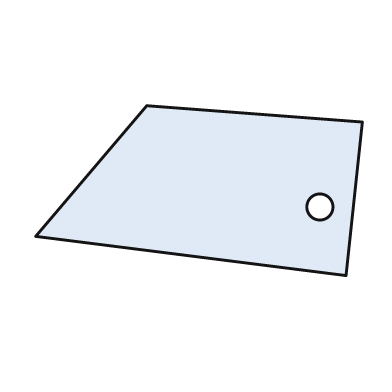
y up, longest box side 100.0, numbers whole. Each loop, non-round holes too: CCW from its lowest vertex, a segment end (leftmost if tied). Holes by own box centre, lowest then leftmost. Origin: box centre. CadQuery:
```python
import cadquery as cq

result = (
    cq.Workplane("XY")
    .moveTo(45.0, -26.0)
    .lineTo(50.0, 21.0)
    .lineTo(-16.0, 26.0)
    .lineTo(-50.0, -14.0)
    .close()
    .moveTo(37.0, -5.0)
    .circle(4.0)
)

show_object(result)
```